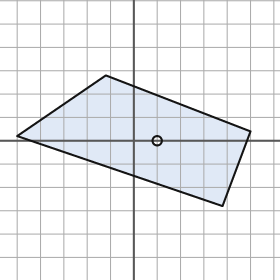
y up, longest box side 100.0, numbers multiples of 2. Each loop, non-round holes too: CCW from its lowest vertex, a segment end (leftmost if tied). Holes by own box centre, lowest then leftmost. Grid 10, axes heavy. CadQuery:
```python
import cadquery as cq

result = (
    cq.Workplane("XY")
    .moveTo(38.0, -28.0)
    .lineTo(50.0, 4.0)
    .lineTo(-12.0, 28.0)
    .lineTo(-50.0, 2.0)
    .close()
    .moveTo(10.0, 0.0)
    .circle(2.0)
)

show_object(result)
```